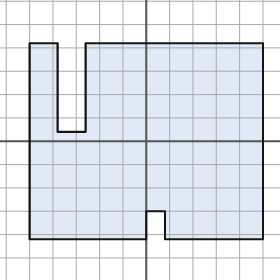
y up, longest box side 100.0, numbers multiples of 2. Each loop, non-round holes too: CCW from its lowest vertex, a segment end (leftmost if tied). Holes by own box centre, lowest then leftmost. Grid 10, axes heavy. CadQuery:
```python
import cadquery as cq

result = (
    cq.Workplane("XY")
    .moveTo(-50.0, -42.0)
    .lineTo(0.0, -42.0)
    .lineTo(0.0, -30.0)
    .lineTo(8.0, -30.0)
    .lineTo(8.0, -42.0)
    .lineTo(50.0, -42.0)
    .lineTo(50.0, 42.0)
    .lineTo(-26.0, 42.0)
    .lineTo(-26.0, 4.0)
    .lineTo(-38.0, 4.0)
    .lineTo(-38.0, 42.0)
    .lineTo(-50.0, 42.0)
    .close()
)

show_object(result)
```